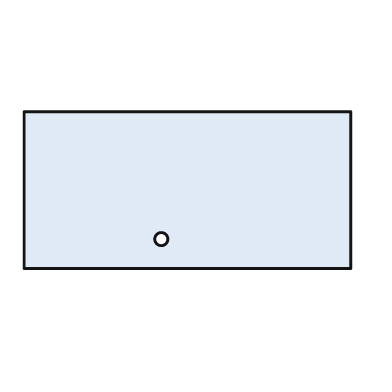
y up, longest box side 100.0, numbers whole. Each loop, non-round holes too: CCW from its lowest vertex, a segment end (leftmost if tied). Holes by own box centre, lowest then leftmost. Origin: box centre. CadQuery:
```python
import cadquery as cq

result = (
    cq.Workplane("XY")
    .moveTo(-50.0, -24.0)
    .lineTo(50.0, -24.0)
    .lineTo(50.0, 24.0)
    .lineTo(-50.0, 24.0)
    .close()
    .moveTo(-8.0, -15.0)
    .circle(2.0)
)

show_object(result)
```